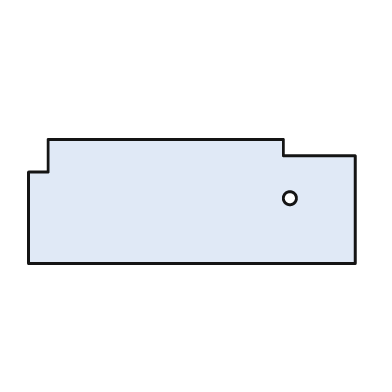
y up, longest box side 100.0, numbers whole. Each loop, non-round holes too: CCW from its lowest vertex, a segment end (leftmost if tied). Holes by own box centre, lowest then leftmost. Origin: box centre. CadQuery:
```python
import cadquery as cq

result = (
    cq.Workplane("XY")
    .moveTo(-50.0, -19.0)
    .lineTo(50.0, -19.0)
    .lineTo(50.0, 14.0)
    .lineTo(28.0, 14.0)
    .lineTo(28.0, 19.0)
    .lineTo(-44.0, 19.0)
    .lineTo(-44.0, 9.0)
    .lineTo(-50.0, 9.0)
    .close()
    .moveTo(30.0, 1.0)
    .circle(2.0)
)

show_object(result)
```